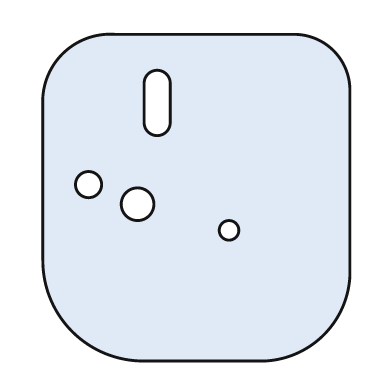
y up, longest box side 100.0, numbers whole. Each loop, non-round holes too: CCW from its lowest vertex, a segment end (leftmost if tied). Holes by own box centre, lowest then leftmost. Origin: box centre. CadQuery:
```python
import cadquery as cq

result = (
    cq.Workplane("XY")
    .moveTo(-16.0, -50.0)
    .lineTo(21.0, -50.0)
    .threePointArc((39.0, -42.0), (47.0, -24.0))
    .lineTo(47.0, 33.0)
    .threePointArc((42.0, 45.0), (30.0, 50.0))
    .lineTo(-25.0, 50.0)
    .threePointArc((-41.0, 44.0), (-47.0, 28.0))
    .lineTo(-47.0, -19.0)
    .threePointArc((-38.0, -41.0), (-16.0, -50.0))
    .close()
    .moveTo(10.0, -10.0)
    .circle(3.0)
    .moveTo(-18.0, -2.0)
    .circle(5.0)
    .moveTo(-33.0, 4.0)
    .circle(4.0)
    .moveTo(-16.0, 23.0)
    .threePointArc((-12.0, 19.0), (-8.0, 23.0))
    .lineTo(-8.0, 35.0)
    .threePointArc((-12.0, 39.0), (-16.0, 35.0))
    .close()
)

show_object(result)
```